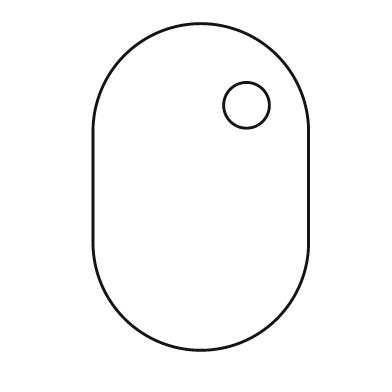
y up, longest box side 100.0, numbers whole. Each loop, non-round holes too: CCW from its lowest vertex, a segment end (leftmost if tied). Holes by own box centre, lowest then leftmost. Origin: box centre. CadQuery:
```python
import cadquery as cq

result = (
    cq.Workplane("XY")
    .moveTo(-33.0, -17.0)
    .threePointArc((0.0, -50.0), (33.0, -17.0))
    .lineTo(33.0, 17.0)
    .threePointArc((0.0, 50.0), (-33.0, 17.0))
    .close()
    .moveTo(14.0, 25.0)
    .circle(7.0)
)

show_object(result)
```